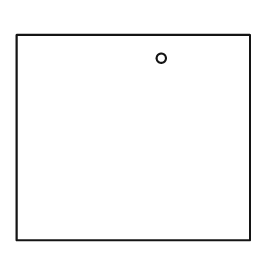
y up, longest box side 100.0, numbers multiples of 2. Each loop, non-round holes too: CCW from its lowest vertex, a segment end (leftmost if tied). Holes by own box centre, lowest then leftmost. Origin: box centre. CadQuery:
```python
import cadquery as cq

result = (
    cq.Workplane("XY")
    .moveTo(-50.0, -44.0)
    .lineTo(50.0, -44.0)
    .lineTo(50.0, 44.0)
    .lineTo(-50.0, 44.0)
    .close()
    .moveTo(12.0, 34.0)
    .circle(2.0)
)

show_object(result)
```